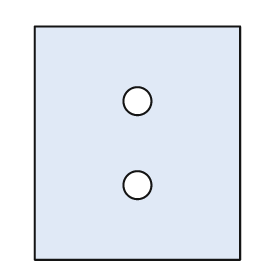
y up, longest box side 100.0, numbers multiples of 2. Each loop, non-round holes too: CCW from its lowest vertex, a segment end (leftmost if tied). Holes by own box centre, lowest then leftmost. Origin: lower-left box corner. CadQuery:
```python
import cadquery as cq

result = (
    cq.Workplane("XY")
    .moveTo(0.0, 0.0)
    .lineTo(88.0, 0.0)
    .lineTo(88.0, 100.0)
    .lineTo(0.0, 100.0)
    .close()
    .moveTo(44.0, 32.0)
    .circle(6.0)
    .moveTo(44.0, 68.0)
    .circle(6.0)
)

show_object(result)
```